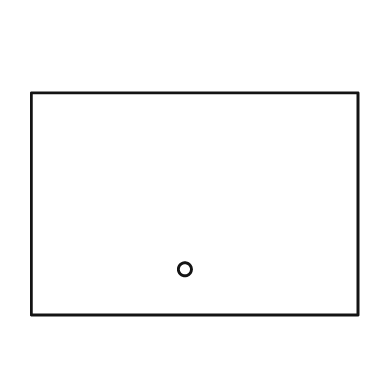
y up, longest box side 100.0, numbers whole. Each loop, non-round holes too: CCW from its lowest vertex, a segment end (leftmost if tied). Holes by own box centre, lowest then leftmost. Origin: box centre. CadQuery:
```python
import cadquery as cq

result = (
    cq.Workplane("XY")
    .moveTo(-50.0, -34.0)
    .lineTo(50.0, -34.0)
    .lineTo(50.0, 34.0)
    .lineTo(-50.0, 34.0)
    .close()
    .moveTo(-3.0, -20.0)
    .circle(2.0)
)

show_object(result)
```